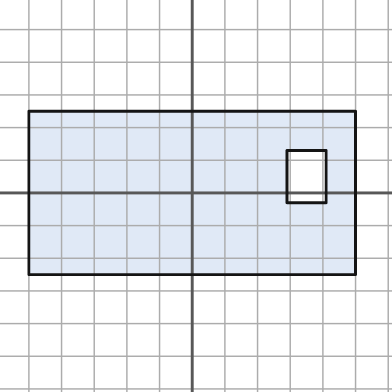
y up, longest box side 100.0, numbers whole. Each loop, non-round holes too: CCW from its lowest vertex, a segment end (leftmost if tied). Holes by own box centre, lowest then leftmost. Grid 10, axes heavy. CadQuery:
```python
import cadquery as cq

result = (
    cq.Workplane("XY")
    .moveTo(-50.0, -25.0)
    .lineTo(50.0, -25.0)
    .lineTo(50.0, 25.0)
    .lineTo(-50.0, 25.0)
    .close()
    .moveTo(29.0, -3.0)
    .lineTo(41.0, -3.0)
    .lineTo(41.0, 13.0)
    .lineTo(29.0, 13.0)
    .close()
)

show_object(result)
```